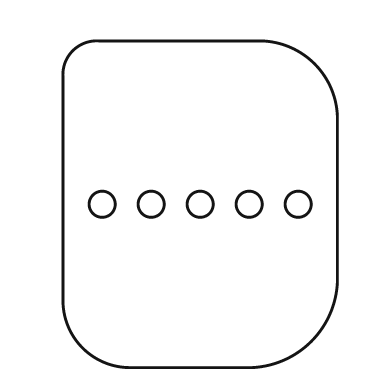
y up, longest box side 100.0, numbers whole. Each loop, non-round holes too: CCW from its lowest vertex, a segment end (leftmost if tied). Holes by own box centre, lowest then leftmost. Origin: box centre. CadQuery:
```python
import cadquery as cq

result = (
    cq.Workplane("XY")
    .moveTo(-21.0, -50.0)
    .lineTo(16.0, -50.0)
    .threePointArc((34.0, -42.0), (42.0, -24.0))
    .lineTo(42.0, 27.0)
    .threePointArc((35.0, 43.0), (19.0, 50.0))
    .lineTo(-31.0, 50.0)
    .threePointArc((-39.0, 47.0), (-42.0, 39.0))
    .lineTo(-42.0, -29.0)
    .threePointArc((-36.0, -44.0), (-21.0, -50.0))
    .close()
    .moveTo(-30.0, 0.0)
    .circle(4.0)
    .moveTo(-15.0, 0.0)
    .circle(4.0)
    .moveTo(0.0, 0.0)
    .circle(4.0)
    .moveTo(15.0, 0.0)
    .circle(4.0)
    .moveTo(30.0, 0.0)
    .circle(4.0)
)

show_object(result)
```